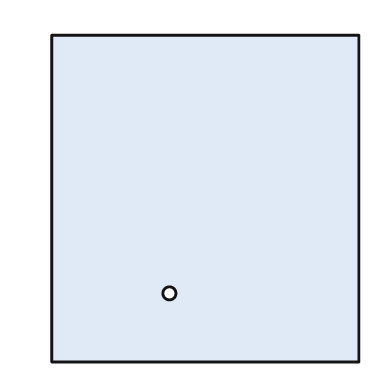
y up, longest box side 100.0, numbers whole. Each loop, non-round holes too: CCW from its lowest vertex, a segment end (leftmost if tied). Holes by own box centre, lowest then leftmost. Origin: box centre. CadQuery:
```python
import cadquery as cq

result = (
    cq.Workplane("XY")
    .moveTo(-47.0, -50.0)
    .lineTo(47.0, -50.0)
    .lineTo(47.0, 50.0)
    .lineTo(-47.0, 50.0)
    .close()
    .moveTo(-11.0, -29.0)
    .circle(2.0)
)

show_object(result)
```